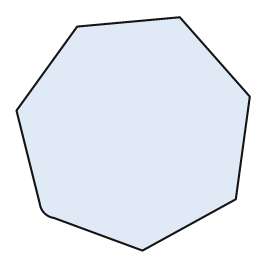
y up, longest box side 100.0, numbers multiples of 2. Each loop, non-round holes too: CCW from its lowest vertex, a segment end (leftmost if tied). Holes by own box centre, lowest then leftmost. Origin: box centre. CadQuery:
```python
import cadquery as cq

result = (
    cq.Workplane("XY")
    .moveTo(4.0, -50.0)
    .lineTo(44.0, -28.0)
    .lineTo(50.0, 16.0)
    .lineTo(20.0, 50.0)
    .lineTo(-24.0, 46.0)
    .lineTo(-50.0, 10.0)
    .lineTo(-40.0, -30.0)
    .threePointArc((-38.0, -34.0), (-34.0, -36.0))
    .close()
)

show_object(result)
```